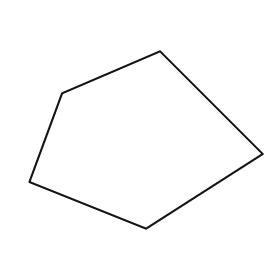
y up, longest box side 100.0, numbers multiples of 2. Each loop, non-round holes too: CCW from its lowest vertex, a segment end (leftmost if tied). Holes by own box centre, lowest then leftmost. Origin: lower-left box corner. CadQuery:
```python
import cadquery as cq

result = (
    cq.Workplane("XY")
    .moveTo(50.0, 0.0)
    .lineTo(100.0, 32.0)
    .lineTo(56.0, 76.0)
    .lineTo(14.0, 58.0)
    .lineTo(0.0, 20.0)
    .close()
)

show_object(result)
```